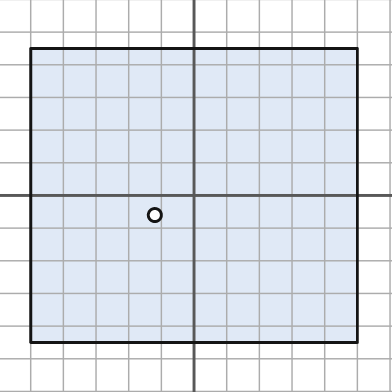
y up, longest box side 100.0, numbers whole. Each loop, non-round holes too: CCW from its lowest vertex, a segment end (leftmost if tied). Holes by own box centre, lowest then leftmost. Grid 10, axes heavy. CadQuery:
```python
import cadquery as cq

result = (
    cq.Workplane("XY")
    .moveTo(-50.0, -45.0)
    .lineTo(50.0, -45.0)
    .lineTo(50.0, 45.0)
    .lineTo(-50.0, 45.0)
    .close()
    .moveTo(-12.0, -6.0)
    .circle(2.0)
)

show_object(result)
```